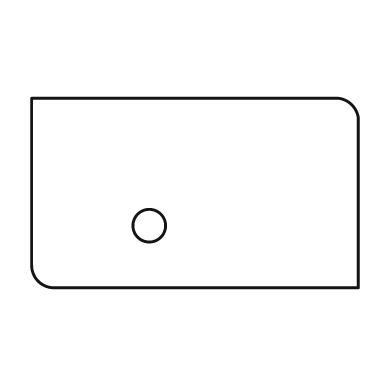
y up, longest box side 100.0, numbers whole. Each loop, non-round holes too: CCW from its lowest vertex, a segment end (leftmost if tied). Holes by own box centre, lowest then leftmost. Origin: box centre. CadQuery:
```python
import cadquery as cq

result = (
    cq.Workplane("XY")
    .moveTo(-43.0, -29.0)
    .lineTo(50.0, -29.0)
    .lineTo(50.0, 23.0)
    .threePointArc((48.0, 27.0), (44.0, 29.0))
    .lineTo(-50.0, 29.0)
    .lineTo(-50.0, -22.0)
    .threePointArc((-48.0, -27.0), (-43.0, -29.0))
    .close()
    .moveTo(-14.0, -10.0)
    .circle(5.0)
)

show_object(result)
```